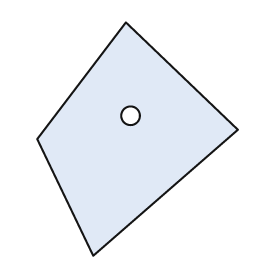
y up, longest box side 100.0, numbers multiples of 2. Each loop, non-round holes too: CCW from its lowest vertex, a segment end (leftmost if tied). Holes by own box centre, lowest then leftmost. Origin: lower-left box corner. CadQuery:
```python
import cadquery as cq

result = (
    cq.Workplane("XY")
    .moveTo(24.0, 0.0)
    .lineTo(86.0, 54.0)
    .lineTo(38.0, 100.0)
    .lineTo(0.0, 50.0)
    .close()
    .moveTo(40.0, 60.0)
    .circle(4.0)
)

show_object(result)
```